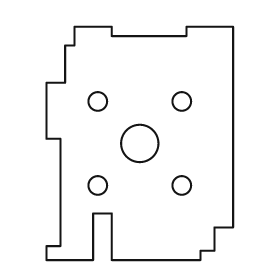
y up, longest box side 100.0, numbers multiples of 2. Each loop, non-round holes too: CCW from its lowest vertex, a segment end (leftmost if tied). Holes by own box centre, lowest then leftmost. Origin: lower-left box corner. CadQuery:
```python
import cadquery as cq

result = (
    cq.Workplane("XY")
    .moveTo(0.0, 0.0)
    .lineTo(20.0, 0.0)
    .lineTo(20.0, 20.0)
    .lineTo(28.0, 20.0)
    .lineTo(28.0, 0.0)
    .lineTo(66.0, 0.0)
    .lineTo(66.0, 4.0)
    .lineTo(72.0, 4.0)
    .lineTo(72.0, 14.0)
    .lineTo(80.0, 14.0)
    .lineTo(80.0, 100.0)
    .lineTo(60.0, 100.0)
    .lineTo(60.0, 96.0)
    .lineTo(28.0, 96.0)
    .lineTo(28.0, 100.0)
    .lineTo(12.0, 100.0)
    .lineTo(12.0, 92.0)
    .lineTo(8.0, 92.0)
    .lineTo(8.0, 76.0)
    .lineTo(0.0, 76.0)
    .lineTo(0.0, 52.0)
    .lineTo(6.0, 52.0)
    .lineTo(6.0, 6.0)
    .lineTo(0.0, 6.0)
    .close()
    .moveTo(22.0, 32.0)
    .circle(4.0)
    .moveTo(58.0, 32.0)
    .circle(4.0)
    .moveTo(40.0, 50.0)
    .circle(8.0)
    .moveTo(22.0, 68.0)
    .circle(4.0)
    .moveTo(58.0, 68.0)
    .circle(4.0)
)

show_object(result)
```